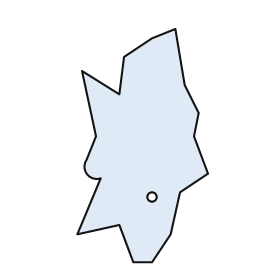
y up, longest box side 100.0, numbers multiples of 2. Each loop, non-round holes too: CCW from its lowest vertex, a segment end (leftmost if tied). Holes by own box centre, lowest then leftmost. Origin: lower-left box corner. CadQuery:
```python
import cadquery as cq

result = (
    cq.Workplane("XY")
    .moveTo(24.0, 0.0)
    .lineTo(32.0, 0.0)
    .lineTo(40.0, 12.0)
    .lineTo(44.0, 30.0)
    .lineTo(56.0, 38.0)
    .lineTo(50.0, 54.0)
    .lineTo(52.0, 64.0)
    .lineTo(46.0, 76.0)
    .lineTo(42.0, 100.0)
    .lineTo(32.0, 96.0)
    .lineTo(20.0, 88.0)
    .lineTo(18.0, 72.0)
    .lineTo(2.0, 82.0)
    .lineTo(8.0, 54.0)
    .lineTo(4.0, 44.0)
    .threePointArc((4.0, 38.0), (10.0, 36.0))
    .lineTo(0.0, 12.0)
    .lineTo(18.0, 16.0)
    .close()
    .moveTo(32.0, 28.0)
    .circle(2.0)
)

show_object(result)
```